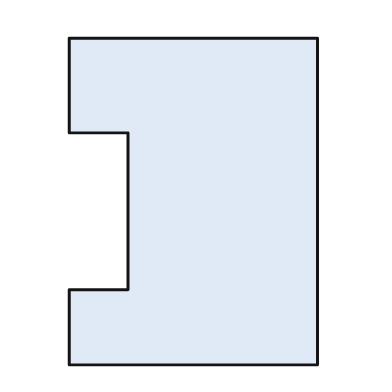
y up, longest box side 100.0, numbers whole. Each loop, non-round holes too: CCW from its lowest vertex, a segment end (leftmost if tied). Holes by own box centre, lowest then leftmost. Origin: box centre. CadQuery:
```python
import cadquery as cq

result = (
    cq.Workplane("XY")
    .moveTo(-38.0, -50.0)
    .lineTo(38.0, -50.0)
    .lineTo(38.0, 50.0)
    .lineTo(-38.0, 50.0)
    .lineTo(-38.0, 21.0)
    .lineTo(-20.0, 21.0)
    .lineTo(-20.0, -27.0)
    .lineTo(-38.0, -27.0)
    .close()
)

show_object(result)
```